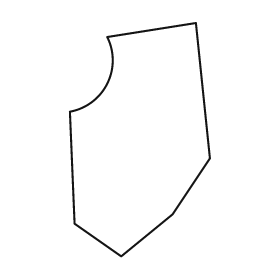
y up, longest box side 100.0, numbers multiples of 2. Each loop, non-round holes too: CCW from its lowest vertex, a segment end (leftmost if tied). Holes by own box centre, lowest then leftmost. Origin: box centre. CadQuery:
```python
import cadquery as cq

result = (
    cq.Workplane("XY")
    .moveTo(-8.0, -50.0)
    .lineTo(14.0, -32.0)
    .lineTo(30.0, -8.0)
    .lineTo(24.0, 50.0)
    .lineTo(-14.0, 44.0)
    .threePointArc((-14.0, 24.0), (-30.0, 12.0))
    .lineTo(-28.0, -36.0)
    .close()
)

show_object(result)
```